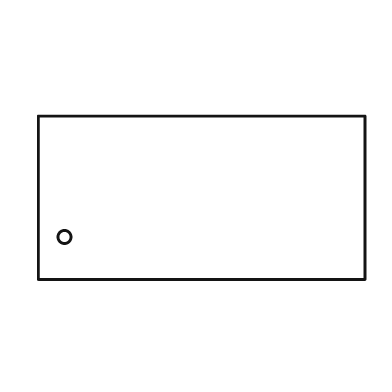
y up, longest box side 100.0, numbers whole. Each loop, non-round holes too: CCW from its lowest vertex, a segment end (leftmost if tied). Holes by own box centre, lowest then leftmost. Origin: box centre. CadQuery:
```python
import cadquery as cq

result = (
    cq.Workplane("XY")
    .moveTo(-50.0, -25.0)
    .lineTo(50.0, -25.0)
    .lineTo(50.0, 25.0)
    .lineTo(-50.0, 25.0)
    .close()
    .moveTo(-42.0, -12.0)
    .circle(2.0)
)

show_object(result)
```